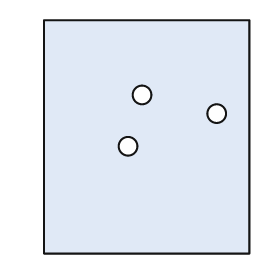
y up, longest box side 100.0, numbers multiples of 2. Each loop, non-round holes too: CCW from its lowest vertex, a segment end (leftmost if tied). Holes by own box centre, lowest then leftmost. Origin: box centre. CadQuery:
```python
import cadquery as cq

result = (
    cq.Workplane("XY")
    .moveTo(-44.0, -50.0)
    .lineTo(44.0, -50.0)
    .lineTo(44.0, 50.0)
    .lineTo(-44.0, 50.0)
    .close()
    .moveTo(-8.0, -4.0)
    .circle(4.0)
    .moveTo(30.0, 10.0)
    .circle(4.0)
    .moveTo(-2.0, 18.0)
    .circle(4.0)
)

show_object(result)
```